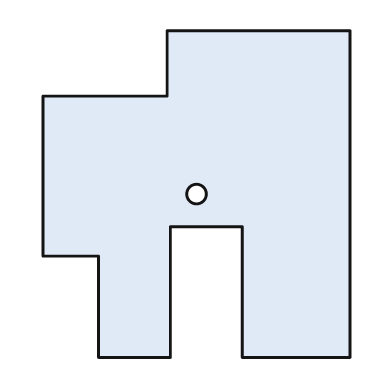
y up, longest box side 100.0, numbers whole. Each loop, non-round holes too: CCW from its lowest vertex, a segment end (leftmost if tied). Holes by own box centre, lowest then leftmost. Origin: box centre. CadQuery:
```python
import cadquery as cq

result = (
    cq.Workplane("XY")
    .moveTo(-30.0, -50.0)
    .lineTo(-8.0, -50.0)
    .lineTo(-8.0, -10.0)
    .lineTo(14.0, -10.0)
    .lineTo(14.0, -50.0)
    .lineTo(47.0, -50.0)
    .lineTo(47.0, 50.0)
    .lineTo(-9.0, 50.0)
    .lineTo(-9.0, 30.0)
    .lineTo(-47.0, 30.0)
    .lineTo(-47.0, -19.0)
    .lineTo(-30.0, -19.0)
    .close()
    .moveTo(0.0, 0.0)
    .circle(3.0)
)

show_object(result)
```